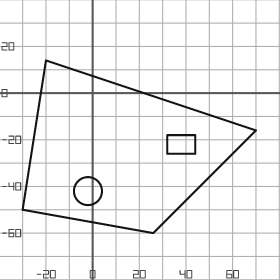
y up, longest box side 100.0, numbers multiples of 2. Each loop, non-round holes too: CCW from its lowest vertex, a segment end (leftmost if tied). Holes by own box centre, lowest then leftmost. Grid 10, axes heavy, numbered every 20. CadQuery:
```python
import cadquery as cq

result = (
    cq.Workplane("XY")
    .moveTo(26.0, -60.0)
    .lineTo(70.0, -16.0)
    .lineTo(-20.0, 14.0)
    .lineTo(-30.0, -50.0)
    .close()
    .moveTo(-2.0, -42.0)
    .circle(6.0)
    .moveTo(32.0, -26.0)
    .lineTo(44.0, -26.0)
    .lineTo(44.0, -18.0)
    .lineTo(32.0, -18.0)
    .close()
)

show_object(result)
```